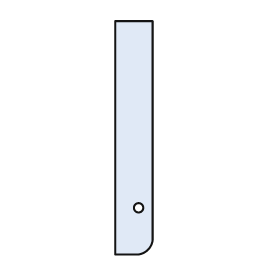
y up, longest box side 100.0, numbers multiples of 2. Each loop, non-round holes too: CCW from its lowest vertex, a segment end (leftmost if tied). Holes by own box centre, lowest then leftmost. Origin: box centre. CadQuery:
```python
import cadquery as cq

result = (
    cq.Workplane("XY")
    .moveTo(-8.0, -50.0)
    .lineTo(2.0, -50.0)
    .threePointArc((6.0, -48.0), (8.0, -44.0))
    .lineTo(8.0, 50.0)
    .lineTo(-8.0, 50.0)
    .close()
    .moveTo(2.0, -30.0)
    .circle(2.0)
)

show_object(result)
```